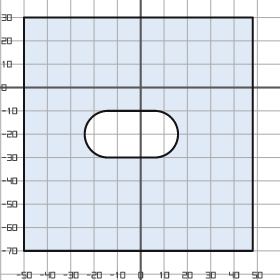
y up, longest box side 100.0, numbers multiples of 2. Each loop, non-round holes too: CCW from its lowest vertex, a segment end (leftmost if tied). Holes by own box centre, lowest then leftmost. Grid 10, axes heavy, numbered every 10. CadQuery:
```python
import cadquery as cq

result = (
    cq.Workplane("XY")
    .moveTo(-50.0, -70.0)
    .lineTo(48.0, -70.0)
    .lineTo(48.0, 30.0)
    .lineTo(-50.0, 30.0)
    .close()
    .moveTo(-14.0, -30.0)
    .lineTo(6.0, -30.0)
    .threePointArc((16.0, -20.0), (6.0, -10.0))
    .lineTo(-14.0, -10.0)
    .threePointArc((-24.0, -20.0), (-14.0, -30.0))
    .close()
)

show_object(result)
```